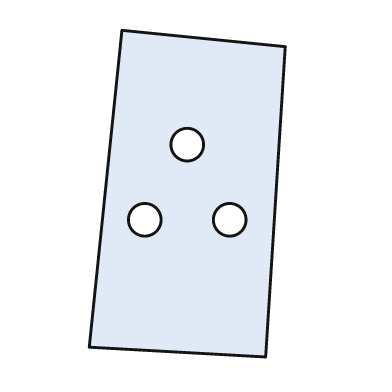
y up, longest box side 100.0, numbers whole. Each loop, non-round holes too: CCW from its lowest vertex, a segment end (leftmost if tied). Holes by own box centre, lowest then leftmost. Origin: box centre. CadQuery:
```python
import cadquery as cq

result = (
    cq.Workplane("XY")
    .moveTo(24.0, -50.0)
    .lineTo(30.0, 45.0)
    .lineTo(-20.0, 50.0)
    .lineTo(-30.0, -47.0)
    .close()
    .moveTo(-13.0, -8.0)
    .circle(5.0)
    .moveTo(13.0, -8.0)
    .circle(5.0)
    .moveTo(0.0, 15.0)
    .circle(5.0)
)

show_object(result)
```